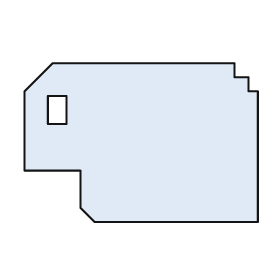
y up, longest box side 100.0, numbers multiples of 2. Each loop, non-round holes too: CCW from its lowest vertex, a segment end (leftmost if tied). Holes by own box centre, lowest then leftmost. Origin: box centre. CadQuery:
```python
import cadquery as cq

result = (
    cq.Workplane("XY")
    .moveTo(-20.0, -34.0)
    .lineTo(50.0, -34.0)
    .lineTo(50.0, 22.0)
    .lineTo(46.0, 22.0)
    .lineTo(46.0, 28.0)
    .lineTo(40.0, 28.0)
    .lineTo(40.0, 34.0)
    .lineTo(-38.0, 34.0)
    .lineTo(-50.0, 22.0)
    .lineTo(-50.0, -12.0)
    .lineTo(-26.0, -12.0)
    .lineTo(-26.0, -28.0)
    .close()
    .moveTo(-40.0, 8.0)
    .lineTo(-32.0, 8.0)
    .lineTo(-32.0, 20.0)
    .lineTo(-40.0, 20.0)
    .close()
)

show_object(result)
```